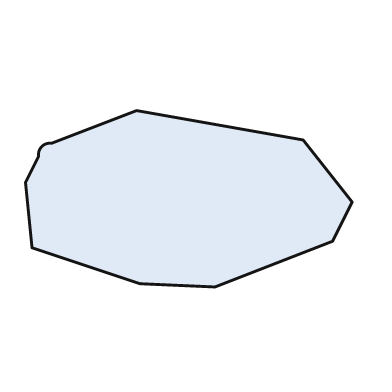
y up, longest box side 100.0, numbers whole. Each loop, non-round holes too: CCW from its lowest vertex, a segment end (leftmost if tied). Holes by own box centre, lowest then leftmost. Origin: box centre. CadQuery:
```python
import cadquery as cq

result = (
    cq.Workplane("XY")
    .moveTo(8.0, -27.0)
    .lineTo(44.0, -13.0)
    .lineTo(50.0, -1.0)
    .lineTo(35.0, 18.0)
    .lineTo(-16.0, 27.0)
    .lineTo(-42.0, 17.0)
    .threePointArc((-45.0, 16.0), (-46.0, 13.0))
    .lineTo(-50.0, 5.0)
    .lineTo(-48.0, -15.0)
    .lineTo(-15.0, -26.0)
    .close()
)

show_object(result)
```